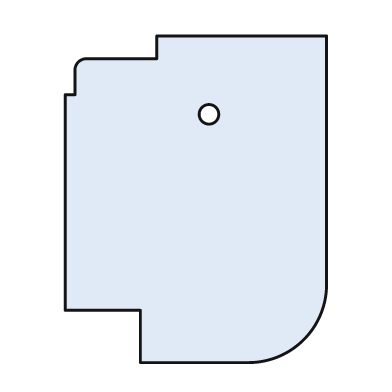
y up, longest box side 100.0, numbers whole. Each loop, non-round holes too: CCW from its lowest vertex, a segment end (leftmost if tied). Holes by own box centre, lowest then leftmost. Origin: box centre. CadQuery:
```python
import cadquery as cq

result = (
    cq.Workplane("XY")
    .moveTo(-17.0, -50.0)
    .lineTo(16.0, -50.0)
    .threePointArc((33.0, -43.0), (40.0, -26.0))
    .lineTo(40.0, 50.0)
    .lineTo(-12.0, 50.0)
    .lineTo(-12.0, 43.0)
    .lineTo(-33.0, 43.0)
    .threePointArc((-36.0, 42.0), (-37.0, 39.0))
    .lineTo(-37.0, 32.0)
    .lineTo(-40.0, 32.0)
    .lineTo(-40.0, -34.0)
    .lineTo(-17.0, -34.0)
    .close()
    .moveTo(4.0, 26.0)
    .circle(3.0)
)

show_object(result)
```